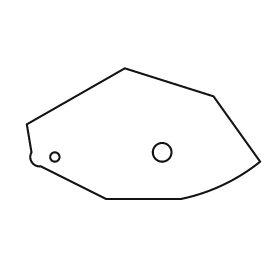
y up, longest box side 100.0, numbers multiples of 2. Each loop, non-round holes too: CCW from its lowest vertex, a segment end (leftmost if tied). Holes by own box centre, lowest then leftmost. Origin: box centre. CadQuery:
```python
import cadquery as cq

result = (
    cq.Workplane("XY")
    .moveTo(-16.0, -28.0)
    .lineTo(16.0, -28.0)
    .threePointArc((34.0, -22.0), (50.0, -12.0))
    .lineTo(30.0, 16.0)
    .lineTo(-8.0, 28.0)
    .lineTo(-50.0, 4.0)
    .lineTo(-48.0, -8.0)
    .threePointArc((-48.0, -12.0), (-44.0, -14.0))
    .close()
    .moveTo(-38.0, -10.0)
    .circle(2.0)
    .moveTo(8.0, -8.0)
    .circle(4.0)
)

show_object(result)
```